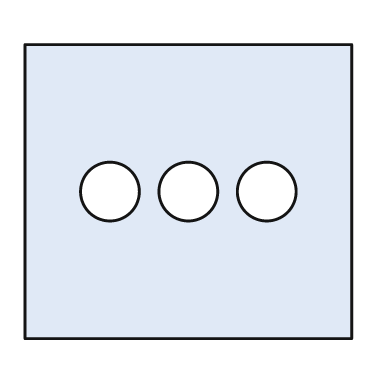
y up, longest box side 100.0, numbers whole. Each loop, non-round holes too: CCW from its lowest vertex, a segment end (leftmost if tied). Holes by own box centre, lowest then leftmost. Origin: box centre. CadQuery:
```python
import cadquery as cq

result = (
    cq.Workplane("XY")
    .moveTo(-50.0, -45.0)
    .lineTo(50.0, -45.0)
    .lineTo(50.0, 45.0)
    .lineTo(-50.0, 45.0)
    .close()
    .moveTo(-24.0, 0.0)
    .circle(9.0)
    .moveTo(0.0, 0.0)
    .circle(9.0)
    .moveTo(24.0, 0.0)
    .circle(9.0)
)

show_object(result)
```